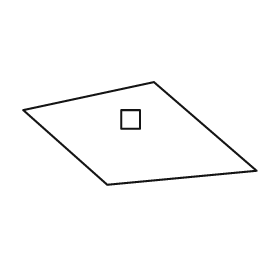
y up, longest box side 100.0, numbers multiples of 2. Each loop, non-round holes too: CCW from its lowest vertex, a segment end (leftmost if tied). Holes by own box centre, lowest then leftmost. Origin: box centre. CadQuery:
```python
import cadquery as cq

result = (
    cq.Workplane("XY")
    .moveTo(-14.0, -22.0)
    .lineTo(50.0, -16.0)
    .lineTo(6.0, 22.0)
    .lineTo(-50.0, 10.0)
    .close()
    .moveTo(-8.0, 2.0)
    .lineTo(0.0, 2.0)
    .lineTo(0.0, 10.0)
    .lineTo(-8.0, 10.0)
    .close()
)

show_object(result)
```